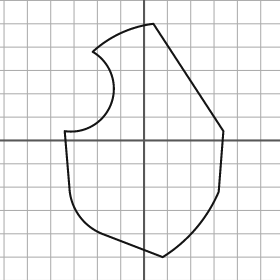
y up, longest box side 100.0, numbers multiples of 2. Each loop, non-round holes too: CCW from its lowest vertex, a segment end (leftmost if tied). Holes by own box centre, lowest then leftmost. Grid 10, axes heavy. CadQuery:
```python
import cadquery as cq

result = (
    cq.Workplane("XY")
    .moveTo(8.0, -50.0)
    .threePointArc((22.0, -38.0), (32.0, -22.0))
    .lineTo(34.0, 4.0)
    .lineTo(4.0, 50.0)
    .threePointArc((-10.0, 46.0), (-22.0, 38.0))
    .threePointArc((-14.0, 16.0), (-34.0, 4.0))
    .lineTo(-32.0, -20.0)
    .threePointArc((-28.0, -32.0), (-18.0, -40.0))
    .close()
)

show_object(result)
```